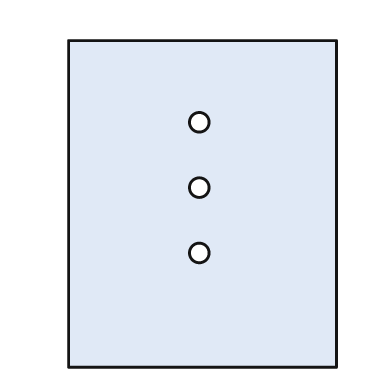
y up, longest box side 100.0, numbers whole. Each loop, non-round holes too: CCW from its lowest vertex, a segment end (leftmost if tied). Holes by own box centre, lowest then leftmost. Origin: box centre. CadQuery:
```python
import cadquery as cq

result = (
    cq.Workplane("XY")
    .moveTo(-41.0, -50.0)
    .lineTo(41.0, -50.0)
    .lineTo(41.0, 50.0)
    .lineTo(-41.0, 50.0)
    .close()
    .moveTo(-1.0, -15.0)
    .circle(3.0)
    .moveTo(-1.0, 5.0)
    .circle(3.0)
    .moveTo(-1.0, 25.0)
    .circle(3.0)
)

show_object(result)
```